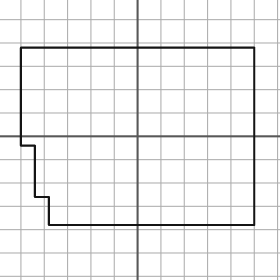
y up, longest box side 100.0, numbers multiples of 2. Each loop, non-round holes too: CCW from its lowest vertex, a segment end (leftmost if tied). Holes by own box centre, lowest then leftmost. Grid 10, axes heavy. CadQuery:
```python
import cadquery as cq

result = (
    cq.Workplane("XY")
    .moveTo(-38.0, -38.0)
    .lineTo(50.0, -38.0)
    .lineTo(50.0, 38.0)
    .lineTo(-50.0, 38.0)
    .lineTo(-50.0, -4.0)
    .lineTo(-44.0, -4.0)
    .lineTo(-44.0, -26.0)
    .lineTo(-38.0, -26.0)
    .close()
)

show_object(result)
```